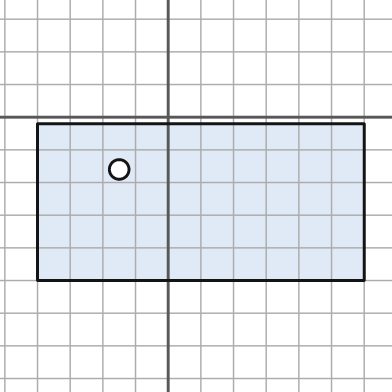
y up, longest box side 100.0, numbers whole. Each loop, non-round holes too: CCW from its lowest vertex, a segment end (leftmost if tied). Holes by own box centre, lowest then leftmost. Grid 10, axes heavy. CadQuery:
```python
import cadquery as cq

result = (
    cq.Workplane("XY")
    .moveTo(-40.0, -50.0)
    .lineTo(60.0, -50.0)
    .lineTo(60.0, -2.0)
    .lineTo(-40.0, -2.0)
    .close()
    .moveTo(-15.0, -16.0)
    .circle(3.0)
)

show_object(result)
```